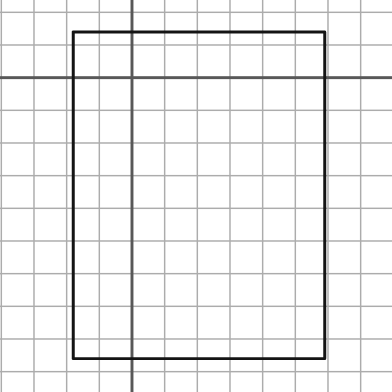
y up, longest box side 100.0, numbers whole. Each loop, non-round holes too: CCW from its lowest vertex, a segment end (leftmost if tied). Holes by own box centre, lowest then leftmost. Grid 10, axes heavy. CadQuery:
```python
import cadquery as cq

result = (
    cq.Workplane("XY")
    .moveTo(-18.0, -86.0)
    .lineTo(59.0, -86.0)
    .lineTo(59.0, 14.0)
    .lineTo(-18.0, 14.0)
    .close()
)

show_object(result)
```